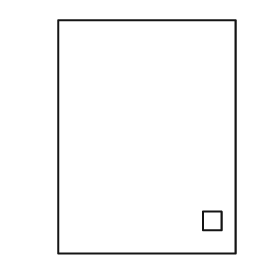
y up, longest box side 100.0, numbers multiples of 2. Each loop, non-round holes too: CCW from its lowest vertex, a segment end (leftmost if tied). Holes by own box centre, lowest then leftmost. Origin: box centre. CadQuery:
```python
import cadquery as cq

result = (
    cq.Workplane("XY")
    .moveTo(-38.0, -50.0)
    .lineTo(38.0, -50.0)
    .lineTo(38.0, 50.0)
    .lineTo(-38.0, 50.0)
    .close()
    .moveTo(24.0, -40.0)
    .lineTo(32.0, -40.0)
    .lineTo(32.0, -32.0)
    .lineTo(24.0, -32.0)
    .close()
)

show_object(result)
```